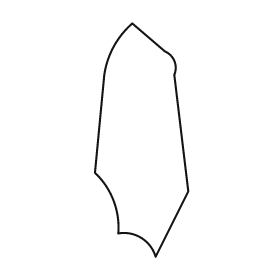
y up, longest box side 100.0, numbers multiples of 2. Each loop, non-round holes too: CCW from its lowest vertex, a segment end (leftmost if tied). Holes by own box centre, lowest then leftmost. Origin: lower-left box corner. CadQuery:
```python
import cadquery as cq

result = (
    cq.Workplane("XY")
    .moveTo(26.0, 0.0)
    .lineTo(40.0, 28.0)
    .lineTo(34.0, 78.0)
    .threePointArc((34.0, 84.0), (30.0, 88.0))
    .lineTo(16.0, 100.0)
    .threePointArc((8.0, 90.0), (4.0, 78.0))
    .lineTo(0.0, 36.0)
    .threePointArc((8.0, 24.0), (10.0, 10.0))
    .threePointArc((20.0, 8.0), (26.0, 0.0))
    .close()
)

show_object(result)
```